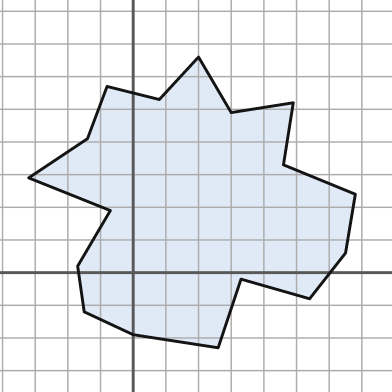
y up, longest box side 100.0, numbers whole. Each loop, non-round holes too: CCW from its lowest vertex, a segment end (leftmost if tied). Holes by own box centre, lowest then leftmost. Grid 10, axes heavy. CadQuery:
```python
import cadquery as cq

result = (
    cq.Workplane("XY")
    .moveTo(26.0, -23.0)
    .lineTo(33.0, -2.0)
    .lineTo(54.0, -8.0)
    .lineTo(65.0, 6.0)
    .lineTo(68.0, 24.0)
    .lineTo(46.0, 33.0)
    .lineTo(49.0, 52.0)
    .lineTo(30.0, 49.0)
    .lineTo(20.0, 66.0)
    .lineTo(8.0, 53.0)
    .lineTo(-8.0, 57.0)
    .lineTo(-14.0, 41.0)
    .lineTo(-32.0, 29.0)
    .lineTo(-7.0, 19.0)
    .lineTo(-17.0, 2.0)
    .lineTo(-15.0, -12.0)
    .lineTo(0.0, -19.0)
    .close()
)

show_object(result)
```